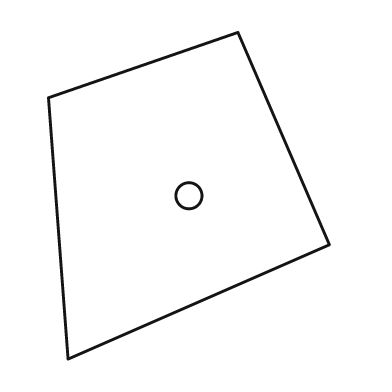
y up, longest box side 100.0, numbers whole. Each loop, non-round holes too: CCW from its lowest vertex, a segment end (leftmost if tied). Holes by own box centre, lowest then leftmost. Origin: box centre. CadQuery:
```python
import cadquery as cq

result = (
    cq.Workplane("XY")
    .moveTo(-37.0, -50.0)
    .lineTo(43.0, -15.0)
    .lineTo(15.0, 50.0)
    .lineTo(-43.0, 30.0)
    .close()
    .moveTo(0.0, 0.0)
    .circle(4.0)
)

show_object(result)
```